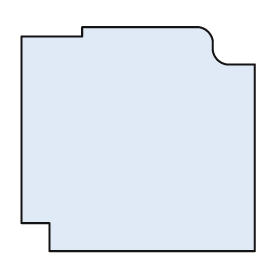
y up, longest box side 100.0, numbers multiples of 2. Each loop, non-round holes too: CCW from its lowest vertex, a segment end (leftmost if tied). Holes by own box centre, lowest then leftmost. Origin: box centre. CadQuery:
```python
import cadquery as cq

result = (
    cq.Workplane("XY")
    .moveTo(-38.0, -48.0)
    .lineTo(50.0, -48.0)
    .lineTo(50.0, 32.0)
    .lineTo(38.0, 32.0)
    .threePointArc((34.0, 34.0), (32.0, 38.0))
    .lineTo(32.0, 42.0)
    .threePointArc((30.0, 46.0), (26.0, 48.0))
    .lineTo(-24.0, 48.0)
    .lineTo(-24.0, 44.0)
    .lineTo(-50.0, 44.0)
    .lineTo(-50.0, -36.0)
    .lineTo(-38.0, -36.0)
    .close()
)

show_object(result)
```